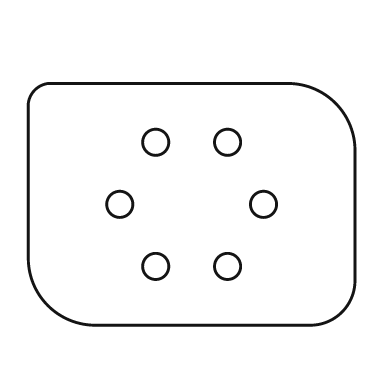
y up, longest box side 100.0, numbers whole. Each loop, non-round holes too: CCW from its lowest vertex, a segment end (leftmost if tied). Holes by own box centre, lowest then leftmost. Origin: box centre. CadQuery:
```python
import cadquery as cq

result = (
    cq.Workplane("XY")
    .moveTo(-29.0, -37.0)
    .lineTo(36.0, -37.0)
    .threePointArc((46.0, -33.0), (50.0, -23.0))
    .lineTo(50.0, 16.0)
    .threePointArc((44.0, 31.0), (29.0, 37.0))
    .lineTo(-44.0, 37.0)
    .threePointArc((-48.0, 35.0), (-50.0, 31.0))
    .lineTo(-50.0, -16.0)
    .threePointArc((-44.0, -31.0), (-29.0, -37.0))
    .close()
    .moveTo(-11.0, -19.0)
    .circle(4.0)
    .moveTo(11.0, -19.0)
    .circle(4.0)
    .moveTo(-22.0, 0.0)
    .circle(4.0)
    .moveTo(22.0, 0.0)
    .circle(4.0)
    .moveTo(-11.0, 19.0)
    .circle(4.0)
    .moveTo(11.0, 19.0)
    .circle(4.0)
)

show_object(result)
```